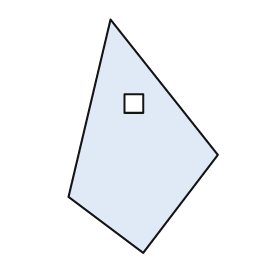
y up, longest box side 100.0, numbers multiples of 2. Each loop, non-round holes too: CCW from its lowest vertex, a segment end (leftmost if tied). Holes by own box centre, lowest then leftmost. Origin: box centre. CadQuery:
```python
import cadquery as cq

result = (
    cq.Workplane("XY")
    .moveTo(0.0, -50.0)
    .lineTo(32.0, -8.0)
    .lineTo(-14.0, 50.0)
    .lineTo(-32.0, -26.0)
    .close()
    .moveTo(-8.0, 10.0)
    .lineTo(0.0, 10.0)
    .lineTo(0.0, 18.0)
    .lineTo(-8.0, 18.0)
    .close()
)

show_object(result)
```